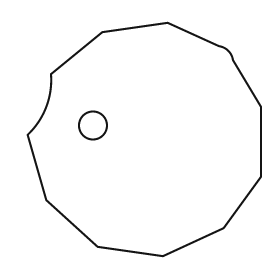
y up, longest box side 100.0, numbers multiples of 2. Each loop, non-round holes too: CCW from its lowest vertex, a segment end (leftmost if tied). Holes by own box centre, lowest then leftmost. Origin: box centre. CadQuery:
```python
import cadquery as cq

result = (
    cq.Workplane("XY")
    .moveTo(8.0, -50.0)
    .lineTo(34.0, -38.0)
    .lineTo(50.0, -16.0)
    .lineTo(50.0, 14.0)
    .lineTo(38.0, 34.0)
    .threePointArc((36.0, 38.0), (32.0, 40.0))
    .lineTo(10.0, 50.0)
    .lineTo(-18.0, 46.0)
    .lineTo(-40.0, 28.0)
    .threePointArc((-42.0, 14.0), (-50.0, 2.0))
    .lineTo(-42.0, -26.0)
    .lineTo(-20.0, -46.0)
    .close()
    .moveTo(-22.0, 6.0)
    .circle(6.0)
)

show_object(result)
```